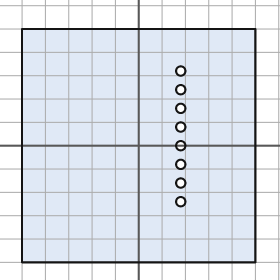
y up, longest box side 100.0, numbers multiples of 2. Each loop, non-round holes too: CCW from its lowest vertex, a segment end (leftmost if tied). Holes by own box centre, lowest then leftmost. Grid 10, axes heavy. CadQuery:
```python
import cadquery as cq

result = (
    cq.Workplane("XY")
    .moveTo(-50.0, -50.0)
    .lineTo(50.0, -50.0)
    .lineTo(50.0, 50.0)
    .lineTo(-50.0, 50.0)
    .close()
    .moveTo(18.0, -24.0)
    .circle(2.0)
    .moveTo(18.0, -16.0)
    .circle(2.0)
    .moveTo(18.0, -8.0)
    .circle(2.0)
    .moveTo(18.0, 0.0)
    .circle(2.0)
    .moveTo(18.0, 8.0)
    .circle(2.0)
    .moveTo(18.0, 16.0)
    .circle(2.0)
    .moveTo(18.0, 24.0)
    .circle(2.0)
    .moveTo(18.0, 32.0)
    .circle(2.0)
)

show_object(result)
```